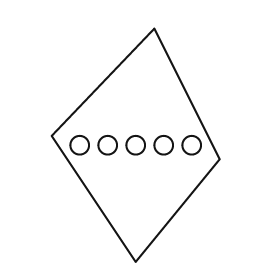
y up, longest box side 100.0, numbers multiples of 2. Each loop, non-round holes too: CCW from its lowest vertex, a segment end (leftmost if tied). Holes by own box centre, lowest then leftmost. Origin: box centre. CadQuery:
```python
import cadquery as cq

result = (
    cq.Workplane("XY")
    .moveTo(0.0, -50.0)
    .lineTo(36.0, -6.0)
    .lineTo(8.0, 50.0)
    .lineTo(-36.0, 4.0)
    .close()
    .moveTo(-24.0, 0.0)
    .circle(4.0)
    .moveTo(-12.0, 0.0)
    .circle(4.0)
    .moveTo(0.0, 0.0)
    .circle(4.0)
    .moveTo(12.0, 0.0)
    .circle(4.0)
    .moveTo(24.0, 0.0)
    .circle(4.0)
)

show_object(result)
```